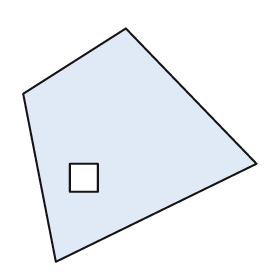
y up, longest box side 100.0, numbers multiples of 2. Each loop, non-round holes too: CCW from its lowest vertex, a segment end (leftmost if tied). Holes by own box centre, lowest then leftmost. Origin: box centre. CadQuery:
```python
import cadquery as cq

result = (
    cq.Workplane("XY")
    .moveTo(-36.0, -50.0)
    .lineTo(50.0, -8.0)
    .lineTo(-6.0, 50.0)
    .lineTo(-50.0, 22.0)
    .close()
    .moveTo(-30.0, -20.0)
    .lineTo(-18.0, -20.0)
    .lineTo(-18.0, -8.0)
    .lineTo(-30.0, -8.0)
    .close()
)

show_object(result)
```